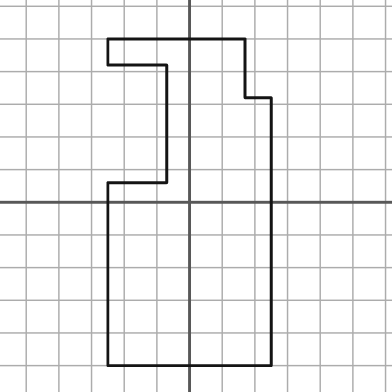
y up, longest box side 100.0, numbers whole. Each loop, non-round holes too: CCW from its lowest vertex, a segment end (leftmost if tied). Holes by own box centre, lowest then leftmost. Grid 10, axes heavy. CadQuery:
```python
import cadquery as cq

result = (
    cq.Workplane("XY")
    .moveTo(-25.0, -50.0)
    .lineTo(25.0, -50.0)
    .lineTo(25.0, 32.0)
    .lineTo(17.0, 32.0)
    .lineTo(17.0, 50.0)
    .lineTo(-25.0, 50.0)
    .lineTo(-25.0, 42.0)
    .lineTo(-7.0, 42.0)
    .lineTo(-7.0, 6.0)
    .lineTo(-25.0, 6.0)
    .close()
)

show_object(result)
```